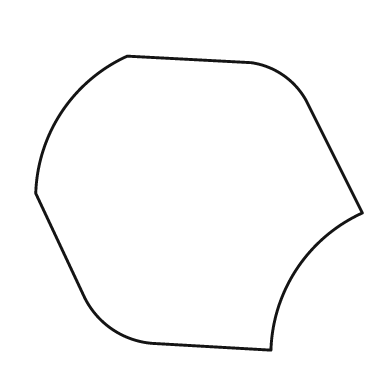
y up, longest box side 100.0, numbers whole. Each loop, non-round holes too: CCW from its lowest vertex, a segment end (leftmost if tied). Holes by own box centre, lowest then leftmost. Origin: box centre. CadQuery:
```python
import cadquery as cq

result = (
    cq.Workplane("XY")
    .moveTo(22.0, -45.0)
    .threePointArc((30.0, -20.0), (50.0, -3.0))
    .lineTo(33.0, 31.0)
    .threePointArc((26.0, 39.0), (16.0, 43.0))
    .lineTo(-22.0, 45.0)
    .threePointArc((-42.0, 28.0), (-50.0, 3.0))
    .lineTo(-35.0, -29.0)
    .threePointArc((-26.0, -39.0), (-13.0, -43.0))
    .close()
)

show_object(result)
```